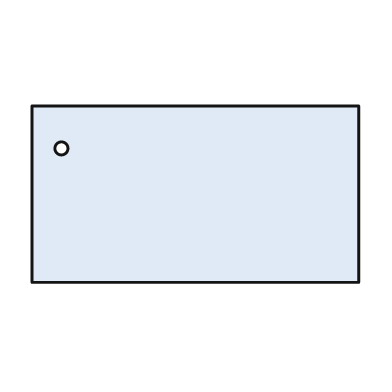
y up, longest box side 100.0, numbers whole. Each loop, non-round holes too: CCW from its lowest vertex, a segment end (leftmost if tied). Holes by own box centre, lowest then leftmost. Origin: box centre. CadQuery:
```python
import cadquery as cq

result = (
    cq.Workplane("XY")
    .moveTo(-50.0, -27.0)
    .lineTo(50.0, -27.0)
    .lineTo(50.0, 27.0)
    .lineTo(-50.0, 27.0)
    .close()
    .moveTo(-41.0, 14.0)
    .circle(2.0)
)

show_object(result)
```